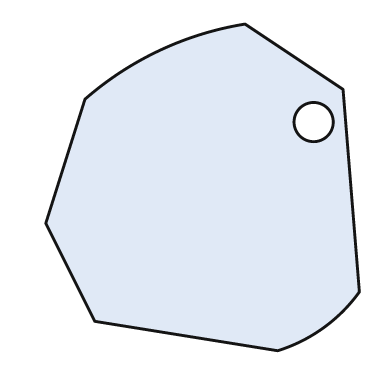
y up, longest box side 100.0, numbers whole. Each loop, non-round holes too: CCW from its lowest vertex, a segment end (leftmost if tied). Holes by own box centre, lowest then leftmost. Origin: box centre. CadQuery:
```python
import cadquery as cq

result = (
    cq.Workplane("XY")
    .moveTo(23.0, -50.0)
    .threePointArc((37.0, -43.0), (48.0, -32.0))
    .lineTo(43.0, 30.0)
    .lineTo(13.0, 50.0)
    .threePointArc((-13.0, 42.0), (-36.0, 27.0))
    .lineTo(-48.0, -11.0)
    .lineTo(-33.0, -41.0)
    .close()
    .moveTo(34.0, 20.0)
    .circle(6.0)
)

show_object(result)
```